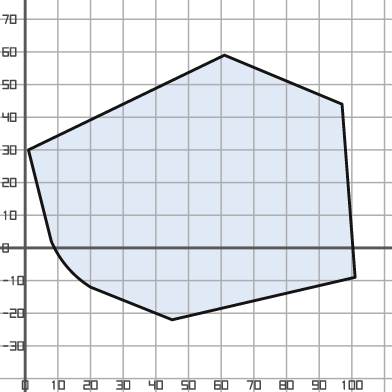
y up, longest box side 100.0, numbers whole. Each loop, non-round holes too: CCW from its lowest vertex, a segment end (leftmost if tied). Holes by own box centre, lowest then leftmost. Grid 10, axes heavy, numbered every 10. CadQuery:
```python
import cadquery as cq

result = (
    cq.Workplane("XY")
    .moveTo(45.0, -22.0)
    .lineTo(101.0, -9.0)
    .lineTo(97.0, 44.0)
    .lineTo(61.0, 59.0)
    .lineTo(1.0, 30.0)
    .lineTo(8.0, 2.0)
    .threePointArc((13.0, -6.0), (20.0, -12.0))
    .close()
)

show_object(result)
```